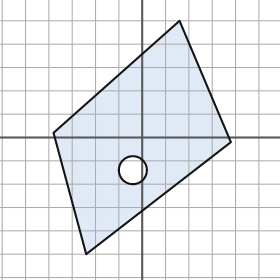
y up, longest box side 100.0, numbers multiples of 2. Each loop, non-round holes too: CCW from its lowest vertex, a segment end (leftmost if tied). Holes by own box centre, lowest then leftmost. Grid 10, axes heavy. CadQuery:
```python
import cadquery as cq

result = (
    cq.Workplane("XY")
    .moveTo(-24.0, -50.0)
    .lineTo(38.0, -2.0)
    .lineTo(16.0, 50.0)
    .lineTo(-38.0, 2.0)
    .close()
    .moveTo(-4.0, -14.0)
    .circle(6.0)
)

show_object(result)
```